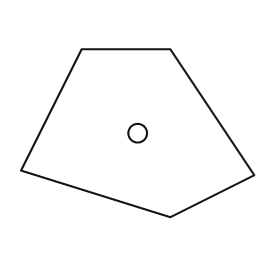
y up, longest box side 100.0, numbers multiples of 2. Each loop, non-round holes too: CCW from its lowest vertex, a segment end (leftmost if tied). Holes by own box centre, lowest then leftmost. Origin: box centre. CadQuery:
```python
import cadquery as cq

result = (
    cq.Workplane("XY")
    .moveTo(14.0, -36.0)
    .lineTo(50.0, -18.0)
    .lineTo(14.0, 36.0)
    .lineTo(-24.0, 36.0)
    .lineTo(-50.0, -16.0)
    .close()
    .moveTo(0.0, 0.0)
    .circle(4.0)
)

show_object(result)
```